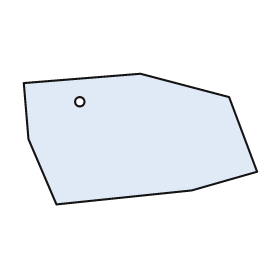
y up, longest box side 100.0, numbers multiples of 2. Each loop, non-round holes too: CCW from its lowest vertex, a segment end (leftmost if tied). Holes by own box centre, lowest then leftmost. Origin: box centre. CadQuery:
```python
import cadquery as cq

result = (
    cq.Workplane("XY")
    .moveTo(-36.0, -28.0)
    .lineTo(22.0, -22.0)
    .lineTo(50.0, -14.0)
    .lineTo(38.0, 18.0)
    .lineTo(0.0, 28.0)
    .lineTo(-50.0, 24.0)
    .lineTo(-48.0, 0.0)
    .close()
    .moveTo(-26.0, 16.0)
    .circle(2.0)
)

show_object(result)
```